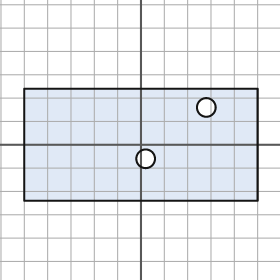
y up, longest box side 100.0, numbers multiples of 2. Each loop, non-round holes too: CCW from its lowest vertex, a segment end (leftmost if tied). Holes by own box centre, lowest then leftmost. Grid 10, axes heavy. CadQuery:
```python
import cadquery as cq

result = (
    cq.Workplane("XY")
    .moveTo(-50.0, -24.0)
    .lineTo(50.0, -24.0)
    .lineTo(50.0, 24.0)
    .lineTo(-50.0, 24.0)
    .close()
    .moveTo(2.0, -6.0)
    .circle(4.0)
    .moveTo(28.0, 16.0)
    .circle(4.0)
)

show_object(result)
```